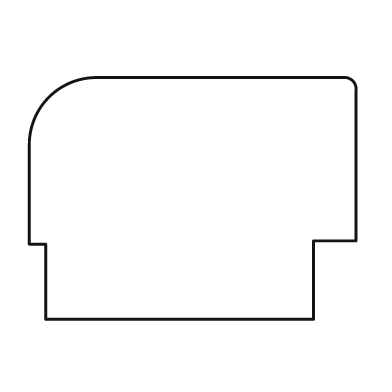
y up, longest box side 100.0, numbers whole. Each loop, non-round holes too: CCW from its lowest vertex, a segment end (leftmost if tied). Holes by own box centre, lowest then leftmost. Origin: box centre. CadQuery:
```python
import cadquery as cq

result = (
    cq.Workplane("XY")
    .moveTo(-45.0, -37.0)
    .lineTo(37.0, -37.0)
    .lineTo(37.0, -13.0)
    .lineTo(50.0, -13.0)
    .lineTo(50.0, 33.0)
    .threePointArc((49.0, 36.0), (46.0, 37.0))
    .lineTo(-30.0, 37.0)
    .threePointArc((-44.0, 31.0), (-50.0, 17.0))
    .lineTo(-50.0, -14.0)
    .lineTo(-45.0, -14.0)
    .close()
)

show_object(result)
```